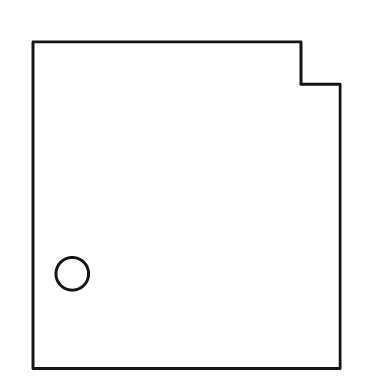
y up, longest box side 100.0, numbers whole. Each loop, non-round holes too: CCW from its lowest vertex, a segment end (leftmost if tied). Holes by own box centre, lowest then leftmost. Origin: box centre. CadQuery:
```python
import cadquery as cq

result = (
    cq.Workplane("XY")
    .moveTo(-47.0, -50.0)
    .lineTo(47.0, -50.0)
    .lineTo(47.0, 37.0)
    .lineTo(35.0, 37.0)
    .lineTo(35.0, 50.0)
    .lineTo(-47.0, 50.0)
    .close()
    .moveTo(-35.0, -21.0)
    .circle(5.0)
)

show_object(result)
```